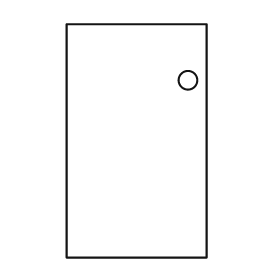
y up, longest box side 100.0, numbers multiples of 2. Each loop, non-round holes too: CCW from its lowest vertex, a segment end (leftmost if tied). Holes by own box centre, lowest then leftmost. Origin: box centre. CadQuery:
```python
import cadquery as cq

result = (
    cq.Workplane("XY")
    .moveTo(-30.0, -50.0)
    .lineTo(30.0, -50.0)
    .lineTo(30.0, 50.0)
    .lineTo(-30.0, 50.0)
    .close()
    .moveTo(22.0, 26.0)
    .circle(4.0)
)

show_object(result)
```